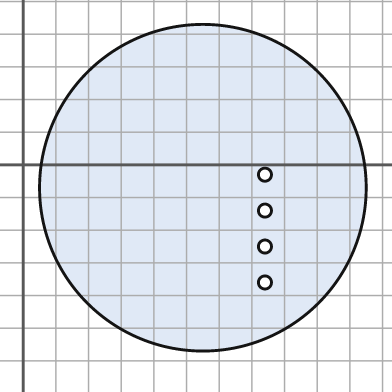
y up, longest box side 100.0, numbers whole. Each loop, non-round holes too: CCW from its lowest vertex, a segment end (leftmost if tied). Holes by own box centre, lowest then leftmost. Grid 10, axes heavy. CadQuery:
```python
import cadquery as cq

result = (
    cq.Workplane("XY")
    .moveTo(55.0, -7.0)
    .circle(50.0)
    .moveTo(74.0, -36.0)
    .circle(2.0)
    .moveTo(74.0, -25.0)
    .circle(2.0)
    .moveTo(74.0, -14.0)
    .circle(2.0)
    .moveTo(74.0, -3.0)
    .circle(2.0)
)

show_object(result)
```